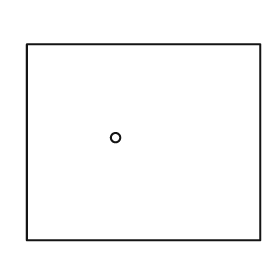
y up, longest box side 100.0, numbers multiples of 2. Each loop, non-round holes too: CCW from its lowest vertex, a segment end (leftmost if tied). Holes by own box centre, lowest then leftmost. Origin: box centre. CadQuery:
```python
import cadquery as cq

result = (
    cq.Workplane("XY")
    .moveTo(-50.0, -42.0)
    .lineTo(50.0, -42.0)
    .lineTo(50.0, 42.0)
    .lineTo(-50.0, 42.0)
    .close()
    .moveTo(-12.0, 2.0)
    .circle(2.0)
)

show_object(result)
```